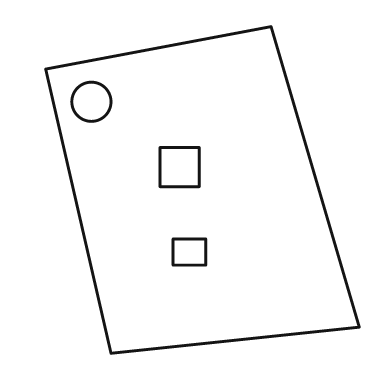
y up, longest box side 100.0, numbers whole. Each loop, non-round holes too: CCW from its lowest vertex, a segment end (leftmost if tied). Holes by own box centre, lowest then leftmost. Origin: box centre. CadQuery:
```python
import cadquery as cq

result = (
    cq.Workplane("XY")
    .moveTo(-28.0, -50.0)
    .lineTo(48.0, -42.0)
    .lineTo(21.0, 50.0)
    .lineTo(-48.0, 37.0)
    .close()
    .moveTo(-9.0, -23.0)
    .lineTo(1.0, -23.0)
    .lineTo(1.0, -15.0)
    .lineTo(-9.0, -15.0)
    .close()
    .moveTo(-13.0, 1.0)
    .lineTo(-1.0, 1.0)
    .lineTo(-1.0, 13.0)
    .lineTo(-13.0, 13.0)
    .close()
    .moveTo(-34.0, 27.0)
    .circle(6.0)
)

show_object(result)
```